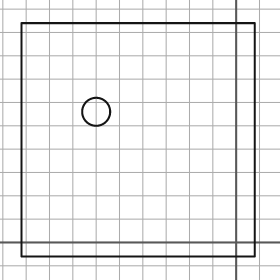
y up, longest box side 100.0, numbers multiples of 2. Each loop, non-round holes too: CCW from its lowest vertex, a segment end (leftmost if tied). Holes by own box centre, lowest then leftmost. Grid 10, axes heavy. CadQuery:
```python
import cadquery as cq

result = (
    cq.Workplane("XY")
    .moveTo(-92.0, -6.0)
    .lineTo(8.0, -6.0)
    .lineTo(8.0, 94.0)
    .lineTo(-92.0, 94.0)
    .close()
    .moveTo(-60.0, 56.0)
    .circle(6.0)
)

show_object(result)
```